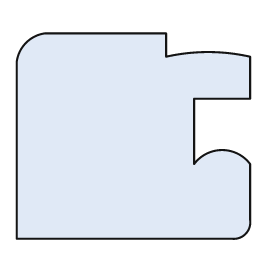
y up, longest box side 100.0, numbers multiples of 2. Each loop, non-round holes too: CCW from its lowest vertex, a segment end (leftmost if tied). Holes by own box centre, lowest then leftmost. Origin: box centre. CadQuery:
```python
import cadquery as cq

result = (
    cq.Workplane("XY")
    .moveTo(-50.0, -44.0)
    .lineTo(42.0, -44.0)
    .threePointArc((48.0, -42.0), (50.0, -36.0))
    .lineTo(50.0, -12.0)
    .threePointArc((38.0, -6.0), (26.0, -12.0))
    .lineTo(26.0, 16.0)
    .lineTo(50.0, 16.0)
    .lineTo(50.0, 34.0)
    .threePointArc((32.0, 36.0), (14.0, 34.0))
    .lineTo(14.0, 44.0)
    .lineTo(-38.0, 44.0)
    .threePointArc((-46.0, 40.0), (-50.0, 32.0))
    .close()
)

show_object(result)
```